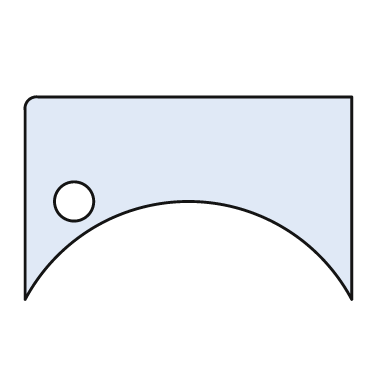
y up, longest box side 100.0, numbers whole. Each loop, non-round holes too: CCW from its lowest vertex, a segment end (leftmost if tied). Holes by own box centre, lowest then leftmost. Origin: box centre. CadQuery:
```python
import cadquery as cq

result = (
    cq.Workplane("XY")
    .moveTo(-50.0, -31.0)
    .threePointArc((0.0, -1.0), (50.0, -31.0))
    .lineTo(50.0, 31.0)
    .lineTo(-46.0, 31.0)
    .threePointArc((-49.0, 30.0), (-50.0, 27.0))
    .close()
    .moveTo(-35.0, -1.0)
    .circle(6.0)
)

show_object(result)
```